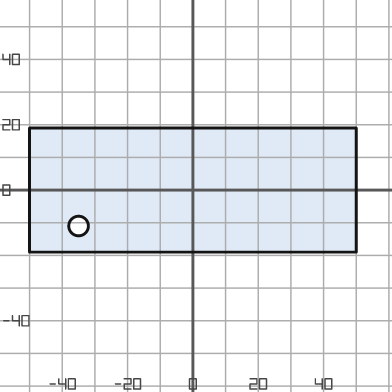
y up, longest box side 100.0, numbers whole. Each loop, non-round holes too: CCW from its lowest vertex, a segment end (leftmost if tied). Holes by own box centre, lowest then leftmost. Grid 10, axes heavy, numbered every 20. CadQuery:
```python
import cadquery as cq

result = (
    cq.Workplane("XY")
    .moveTo(-50.0, -19.0)
    .lineTo(50.0, -19.0)
    .lineTo(50.0, 19.0)
    .lineTo(-50.0, 19.0)
    .close()
    .moveTo(-35.0, -11.0)
    .circle(3.0)
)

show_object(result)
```